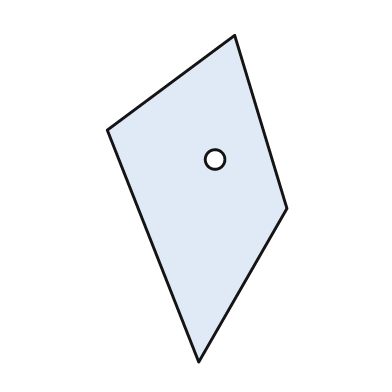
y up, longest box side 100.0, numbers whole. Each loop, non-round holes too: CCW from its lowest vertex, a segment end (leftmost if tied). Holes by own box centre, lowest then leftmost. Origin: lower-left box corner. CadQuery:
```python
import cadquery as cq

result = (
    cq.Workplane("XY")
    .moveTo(28.0, 0.0)
    .lineTo(55.0, 47.0)
    .lineTo(39.0, 100.0)
    .lineTo(0.0, 71.0)
    .close()
    .moveTo(33.0, 62.0)
    .circle(3.0)
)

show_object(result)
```